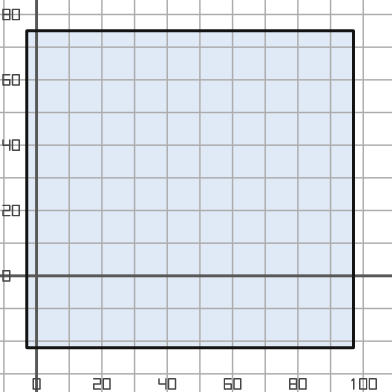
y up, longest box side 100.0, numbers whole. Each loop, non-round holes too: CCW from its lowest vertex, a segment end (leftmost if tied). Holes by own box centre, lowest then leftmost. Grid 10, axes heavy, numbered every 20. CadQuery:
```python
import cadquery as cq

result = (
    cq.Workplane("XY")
    .moveTo(-3.0, -22.0)
    .lineTo(97.0, -22.0)
    .lineTo(97.0, 75.0)
    .lineTo(-3.0, 75.0)
    .close()
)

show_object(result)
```